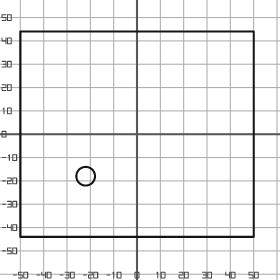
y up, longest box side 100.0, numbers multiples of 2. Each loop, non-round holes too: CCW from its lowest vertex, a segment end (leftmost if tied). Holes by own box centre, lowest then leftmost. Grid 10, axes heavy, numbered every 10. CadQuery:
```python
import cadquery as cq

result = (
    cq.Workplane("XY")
    .moveTo(-50.0, -44.0)
    .lineTo(50.0, -44.0)
    .lineTo(50.0, 44.0)
    .lineTo(-50.0, 44.0)
    .close()
    .moveTo(-22.0, -18.0)
    .circle(4.0)
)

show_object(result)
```